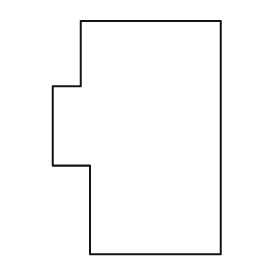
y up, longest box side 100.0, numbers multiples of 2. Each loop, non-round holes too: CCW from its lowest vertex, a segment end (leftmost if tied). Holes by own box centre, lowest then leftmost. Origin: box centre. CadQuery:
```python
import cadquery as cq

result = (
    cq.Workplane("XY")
    .moveTo(-20.0, -50.0)
    .lineTo(36.0, -50.0)
    .lineTo(36.0, 50.0)
    .lineTo(-24.0, 50.0)
    .lineTo(-24.0, 22.0)
    .lineTo(-36.0, 22.0)
    .lineTo(-36.0, -12.0)
    .lineTo(-20.0, -12.0)
    .close()
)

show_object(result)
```